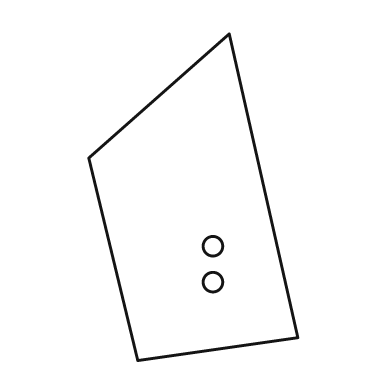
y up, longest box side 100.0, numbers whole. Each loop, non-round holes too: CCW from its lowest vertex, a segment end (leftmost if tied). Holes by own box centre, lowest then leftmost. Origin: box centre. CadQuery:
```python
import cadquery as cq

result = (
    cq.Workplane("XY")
    .moveTo(-17.0, -50.0)
    .lineTo(32.0, -43.0)
    .lineTo(11.0, 50.0)
    .lineTo(-32.0, 12.0)
    .close()
    .moveTo(6.0, -26.0)
    .circle(3.0)
    .moveTo(6.0, -15.0)
    .circle(3.0)
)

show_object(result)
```